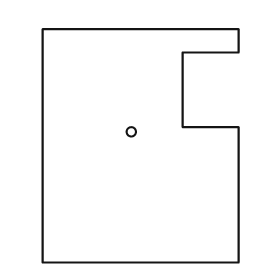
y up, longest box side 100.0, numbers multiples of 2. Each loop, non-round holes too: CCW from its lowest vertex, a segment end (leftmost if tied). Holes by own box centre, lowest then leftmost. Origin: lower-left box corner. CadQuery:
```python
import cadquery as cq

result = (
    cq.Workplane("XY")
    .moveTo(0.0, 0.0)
    .lineTo(84.0, 0.0)
    .lineTo(84.0, 58.0)
    .lineTo(60.0, 58.0)
    .lineTo(60.0, 90.0)
    .lineTo(84.0, 90.0)
    .lineTo(84.0, 100.0)
    .lineTo(0.0, 100.0)
    .close()
    .moveTo(38.0, 56.0)
    .circle(2.0)
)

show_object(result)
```